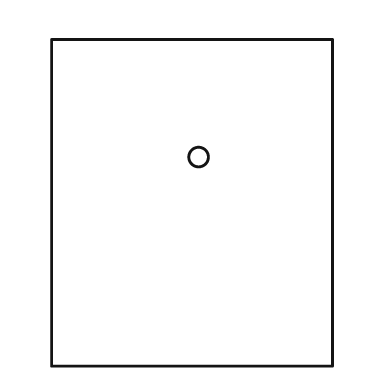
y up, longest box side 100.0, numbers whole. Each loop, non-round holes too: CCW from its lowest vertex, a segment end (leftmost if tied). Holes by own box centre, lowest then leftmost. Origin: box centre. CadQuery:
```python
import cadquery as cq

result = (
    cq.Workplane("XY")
    .moveTo(-43.0, -50.0)
    .lineTo(43.0, -50.0)
    .lineTo(43.0, 50.0)
    .lineTo(-43.0, 50.0)
    .close()
    .moveTo(2.0, 14.0)
    .circle(3.0)
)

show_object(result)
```